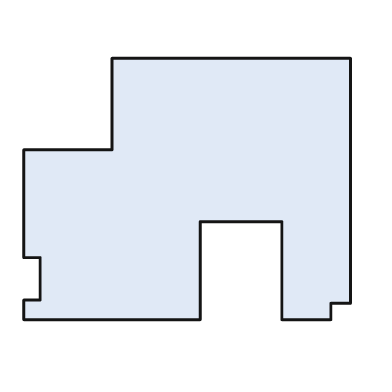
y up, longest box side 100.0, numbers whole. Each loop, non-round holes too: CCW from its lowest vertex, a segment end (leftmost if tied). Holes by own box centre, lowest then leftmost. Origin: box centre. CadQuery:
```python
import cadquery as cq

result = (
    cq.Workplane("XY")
    .moveTo(-50.0, -40.0)
    .lineTo(4.0, -40.0)
    .lineTo(4.0, -10.0)
    .lineTo(29.0, -10.0)
    .lineTo(29.0, -40.0)
    .lineTo(44.0, -40.0)
    .lineTo(44.0, -35.0)
    .lineTo(50.0, -35.0)
    .lineTo(50.0, 40.0)
    .lineTo(-23.0, 40.0)
    .lineTo(-23.0, 12.0)
    .lineTo(-50.0, 12.0)
    .lineTo(-50.0, -21.0)
    .lineTo(-45.0, -21.0)
    .lineTo(-45.0, -34.0)
    .lineTo(-50.0, -34.0)
    .close()
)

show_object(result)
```